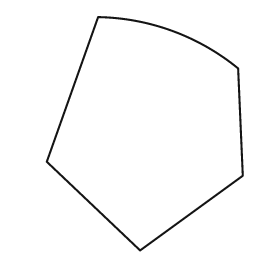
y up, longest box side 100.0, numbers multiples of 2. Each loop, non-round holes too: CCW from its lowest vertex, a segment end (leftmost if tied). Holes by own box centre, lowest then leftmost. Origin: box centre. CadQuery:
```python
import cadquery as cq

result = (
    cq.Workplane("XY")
    .moveTo(-2.0, -50.0)
    .lineTo(42.0, -18.0)
    .lineTo(40.0, 28.0)
    .threePointArc((12.0, 44.0), (-20.0, 50.0))
    .lineTo(-42.0, -12.0)
    .close()
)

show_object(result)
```